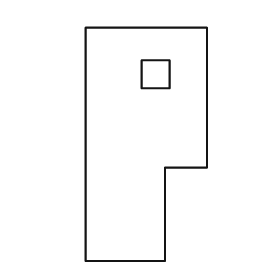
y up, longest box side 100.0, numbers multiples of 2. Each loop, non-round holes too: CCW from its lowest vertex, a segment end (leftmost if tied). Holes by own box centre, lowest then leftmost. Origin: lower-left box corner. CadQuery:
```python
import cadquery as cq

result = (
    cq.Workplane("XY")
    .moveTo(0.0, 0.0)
    .lineTo(34.0, 0.0)
    .lineTo(34.0, 40.0)
    .lineTo(52.0, 40.0)
    .lineTo(52.0, 100.0)
    .lineTo(0.0, 100.0)
    .close()
    .moveTo(24.0, 74.0)
    .lineTo(36.0, 74.0)
    .lineTo(36.0, 86.0)
    .lineTo(24.0, 86.0)
    .close()
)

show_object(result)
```